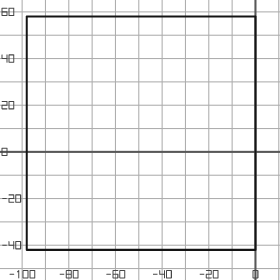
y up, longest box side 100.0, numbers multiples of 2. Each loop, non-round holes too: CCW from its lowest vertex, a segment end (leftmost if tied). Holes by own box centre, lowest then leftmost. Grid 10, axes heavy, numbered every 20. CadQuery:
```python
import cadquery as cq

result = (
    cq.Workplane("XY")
    .moveTo(-98.0, -42.0)
    .lineTo(0.0, -42.0)
    .lineTo(0.0, 58.0)
    .lineTo(-98.0, 58.0)
    .close()
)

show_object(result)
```